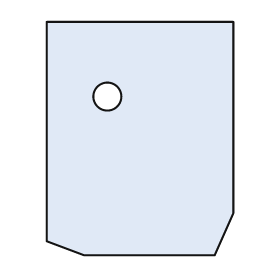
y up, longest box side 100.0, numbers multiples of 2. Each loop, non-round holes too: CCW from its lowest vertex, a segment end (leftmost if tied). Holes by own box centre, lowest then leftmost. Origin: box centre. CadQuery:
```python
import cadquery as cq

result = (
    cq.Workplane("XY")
    .moveTo(-24.0, -50.0)
    .lineTo(32.0, -50.0)
    .lineTo(40.0, -32.0)
    .lineTo(40.0, 50.0)
    .lineTo(-40.0, 50.0)
    .lineTo(-40.0, -44.0)
    .close()
    .moveTo(-14.0, 18.0)
    .circle(6.0)
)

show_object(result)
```